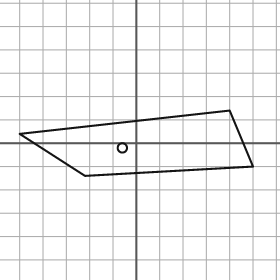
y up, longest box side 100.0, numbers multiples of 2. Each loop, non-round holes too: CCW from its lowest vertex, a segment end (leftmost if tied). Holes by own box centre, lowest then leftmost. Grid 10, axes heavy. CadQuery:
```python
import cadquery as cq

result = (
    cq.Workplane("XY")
    .moveTo(-22.0, -14.0)
    .lineTo(50.0, -10.0)
    .lineTo(40.0, 14.0)
    .lineTo(-50.0, 4.0)
    .close()
    .moveTo(-6.0, -2.0)
    .circle(2.0)
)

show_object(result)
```